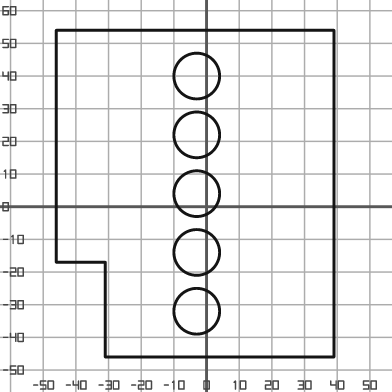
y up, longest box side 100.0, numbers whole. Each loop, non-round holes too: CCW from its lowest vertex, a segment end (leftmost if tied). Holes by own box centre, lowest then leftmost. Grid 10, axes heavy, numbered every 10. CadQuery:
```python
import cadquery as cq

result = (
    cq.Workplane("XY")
    .moveTo(-31.0, -46.0)
    .lineTo(39.0, -46.0)
    .lineTo(39.0, 54.0)
    .lineTo(-46.0, 54.0)
    .lineTo(-46.0, -17.0)
    .lineTo(-31.0, -17.0)
    .close()
    .moveTo(-3.0, -32.0)
    .circle(7.0)
    .moveTo(-3.0, -14.0)
    .circle(7.0)
    .moveTo(-3.0, 4.0)
    .circle(7.0)
    .moveTo(-3.0, 22.0)
    .circle(7.0)
    .moveTo(-3.0, 40.0)
    .circle(7.0)
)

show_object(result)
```